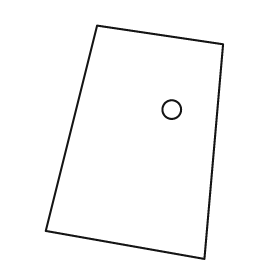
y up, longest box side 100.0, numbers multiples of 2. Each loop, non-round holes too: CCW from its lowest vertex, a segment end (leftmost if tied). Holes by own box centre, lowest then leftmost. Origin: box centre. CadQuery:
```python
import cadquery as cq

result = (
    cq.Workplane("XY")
    .moveTo(30.0, -50.0)
    .lineTo(38.0, 42.0)
    .lineTo(-16.0, 50.0)
    .lineTo(-38.0, -38.0)
    .close()
    .moveTo(16.0, 14.0)
    .circle(4.0)
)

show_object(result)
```